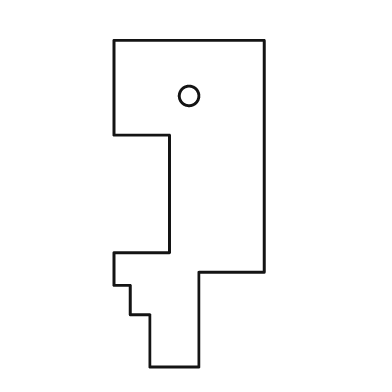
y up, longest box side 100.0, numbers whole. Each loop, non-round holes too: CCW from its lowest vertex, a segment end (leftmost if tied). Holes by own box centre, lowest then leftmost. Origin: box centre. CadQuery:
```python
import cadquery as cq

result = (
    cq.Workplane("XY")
    .moveTo(-12.0, -50.0)
    .lineTo(3.0, -50.0)
    .lineTo(3.0, -21.0)
    .lineTo(23.0, -21.0)
    .lineTo(23.0, 50.0)
    .lineTo(-23.0, 50.0)
    .lineTo(-23.0, 21.0)
    .lineTo(-6.0, 21.0)
    .lineTo(-6.0, -15.0)
    .lineTo(-23.0, -15.0)
    .lineTo(-23.0, -25.0)
    .lineTo(-18.0, -25.0)
    .lineTo(-18.0, -34.0)
    .lineTo(-12.0, -34.0)
    .close()
    .moveTo(0.0, 33.0)
    .circle(3.0)
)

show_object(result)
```